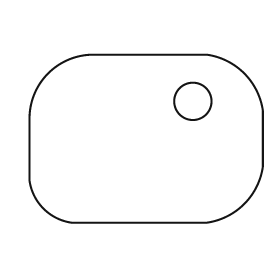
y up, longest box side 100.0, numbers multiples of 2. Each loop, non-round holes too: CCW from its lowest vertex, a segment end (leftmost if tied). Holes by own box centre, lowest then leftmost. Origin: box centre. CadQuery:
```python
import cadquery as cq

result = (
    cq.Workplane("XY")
    .moveTo(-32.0, -36.0)
    .lineTo(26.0, -36.0)
    .threePointArc((42.0, -28.0), (50.0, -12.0))
    .lineTo(50.0, 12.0)
    .threePointArc((42.0, 28.0), (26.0, 36.0))
    .lineTo(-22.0, 36.0)
    .threePointArc((-42.0, 28.0), (-50.0, 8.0))
    .lineTo(-50.0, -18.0)
    .threePointArc((-44.0, -30.0), (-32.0, -36.0))
    .close()
    .moveTo(20.0, 16.0)
    .circle(8.0)
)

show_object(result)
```